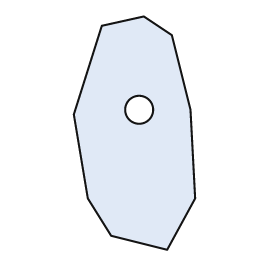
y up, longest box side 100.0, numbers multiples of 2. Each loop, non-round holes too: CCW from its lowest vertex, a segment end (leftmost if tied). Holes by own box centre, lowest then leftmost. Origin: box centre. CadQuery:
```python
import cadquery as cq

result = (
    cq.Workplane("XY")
    .moveTo(14.0, -50.0)
    .lineTo(26.0, -28.0)
    .lineTo(24.0, 10.0)
    .lineTo(16.0, 42.0)
    .lineTo(4.0, 50.0)
    .lineTo(-14.0, 46.0)
    .lineTo(-26.0, 8.0)
    .lineTo(-20.0, -28.0)
    .lineTo(-10.0, -44.0)
    .close()
    .moveTo(2.0, 10.0)
    .circle(6.0)
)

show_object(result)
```